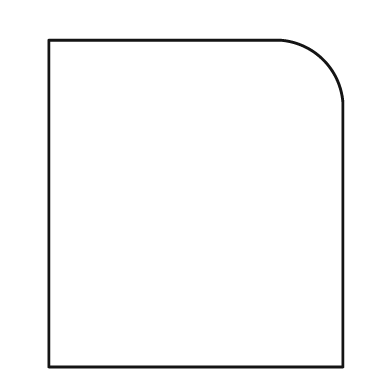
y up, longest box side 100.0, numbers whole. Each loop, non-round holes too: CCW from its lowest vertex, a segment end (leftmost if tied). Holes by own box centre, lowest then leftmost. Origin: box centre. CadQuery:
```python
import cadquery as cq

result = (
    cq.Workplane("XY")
    .moveTo(-45.0, -50.0)
    .lineTo(45.0, -50.0)
    .lineTo(45.0, 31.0)
    .threePointArc((39.0, 44.0), (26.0, 50.0))
    .lineTo(-45.0, 50.0)
    .close()
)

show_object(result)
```